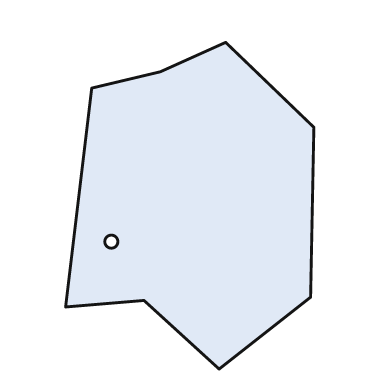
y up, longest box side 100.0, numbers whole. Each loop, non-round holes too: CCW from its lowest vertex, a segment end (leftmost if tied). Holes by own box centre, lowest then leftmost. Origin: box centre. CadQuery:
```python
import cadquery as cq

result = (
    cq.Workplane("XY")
    .moveTo(9.0, -50.0)
    .lineTo(37.0, -28.0)
    .lineTo(38.0, 24.0)
    .lineTo(11.0, 50.0)
    .lineTo(-9.0, 41.0)
    .lineTo(-30.0, 36.0)
    .lineTo(-38.0, -31.0)
    .lineTo(-14.0, -29.0)
    .close()
    .moveTo(-24.0, -11.0)
    .circle(2.0)
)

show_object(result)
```